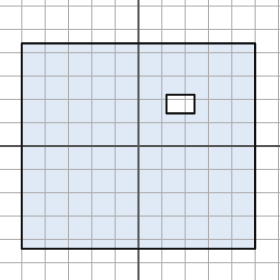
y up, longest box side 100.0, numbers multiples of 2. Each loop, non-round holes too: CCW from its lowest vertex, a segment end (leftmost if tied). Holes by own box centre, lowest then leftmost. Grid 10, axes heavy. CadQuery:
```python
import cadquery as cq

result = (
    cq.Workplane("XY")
    .moveTo(-50.0, -44.0)
    .lineTo(50.0, -44.0)
    .lineTo(50.0, 44.0)
    .lineTo(-50.0, 44.0)
    .close()
    .moveTo(12.0, 14.0)
    .lineTo(24.0, 14.0)
    .lineTo(24.0, 22.0)
    .lineTo(12.0, 22.0)
    .close()
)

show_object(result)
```